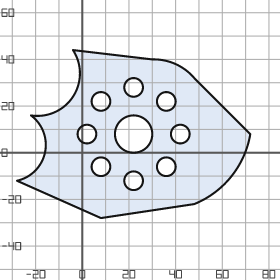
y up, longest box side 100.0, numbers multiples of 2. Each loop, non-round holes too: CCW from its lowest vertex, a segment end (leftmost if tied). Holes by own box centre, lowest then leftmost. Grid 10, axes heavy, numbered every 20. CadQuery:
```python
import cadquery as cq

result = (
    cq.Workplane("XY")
    .moveTo(8.0, -28.0)
    .lineTo(48.0, -22.0)
    .threePointArc((64.0, -10.0), (72.0, 8.0))
    .lineTo(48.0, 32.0)
    .threePointArc((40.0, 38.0), (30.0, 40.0))
    .lineTo(-4.0, 44.0)
    .threePointArc((-4.0, 24.0), (-22.0, 16.0))
    .threePointArc((-16.0, 0.0), (-28.0, -12.0))
    .close()
    .moveTo(22.0, -12.0)
    .circle(4.0)
    .moveTo(8.0, -6.0)
    .circle(4.0)
    .moveTo(36.0, -6.0)
    .circle(4.0)
    .moveTo(2.0, 8.0)
    .circle(4.0)
    .moveTo(22.0, 8.0)
    .circle(8.0)
    .moveTo(42.0, 8.0)
    .circle(4.0)
    .moveTo(8.0, 22.0)
    .circle(4.0)
    .moveTo(36.0, 22.0)
    .circle(4.0)
    .moveTo(22.0, 28.0)
    .circle(4.0)
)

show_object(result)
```